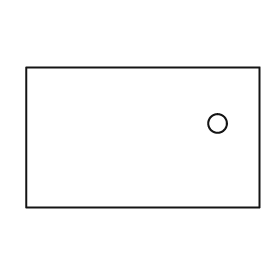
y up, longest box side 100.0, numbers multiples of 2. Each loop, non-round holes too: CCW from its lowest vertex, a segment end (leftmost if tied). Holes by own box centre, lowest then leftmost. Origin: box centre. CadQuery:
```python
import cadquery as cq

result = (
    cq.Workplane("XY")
    .moveTo(-50.0, -30.0)
    .lineTo(50.0, -30.0)
    .lineTo(50.0, 30.0)
    .lineTo(-50.0, 30.0)
    .close()
    .moveTo(32.0, 6.0)
    .circle(4.0)
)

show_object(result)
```